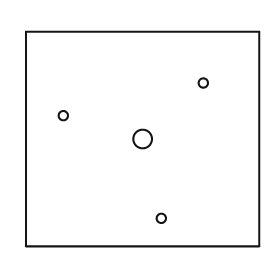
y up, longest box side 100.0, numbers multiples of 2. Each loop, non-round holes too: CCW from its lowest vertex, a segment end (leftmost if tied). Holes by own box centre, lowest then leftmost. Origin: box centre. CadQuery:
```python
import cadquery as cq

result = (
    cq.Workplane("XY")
    .moveTo(-50.0, -46.0)
    .lineTo(50.0, -46.0)
    .lineTo(50.0, 46.0)
    .lineTo(-50.0, 46.0)
    .close()
    .moveTo(8.0, -34.0)
    .circle(2.0)
    .moveTo(0.0, 0.0)
    .circle(4.0)
    .moveTo(-34.0, 10.0)
    .circle(2.0)
    .moveTo(26.0, 24.0)
    .circle(2.0)
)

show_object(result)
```